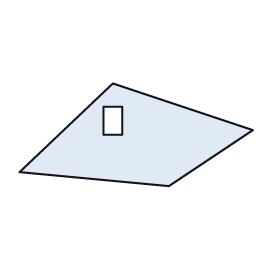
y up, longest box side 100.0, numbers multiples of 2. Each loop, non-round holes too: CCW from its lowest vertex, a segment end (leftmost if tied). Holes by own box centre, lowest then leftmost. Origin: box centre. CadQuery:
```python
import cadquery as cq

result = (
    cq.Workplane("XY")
    .moveTo(14.0, -22.0)
    .lineTo(50.0, 2.0)
    .lineTo(-10.0, 22.0)
    .lineTo(-50.0, -16.0)
    .close()
    .moveTo(-14.0, 0.0)
    .lineTo(-6.0, 0.0)
    .lineTo(-6.0, 12.0)
    .lineTo(-14.0, 12.0)
    .close()
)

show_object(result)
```